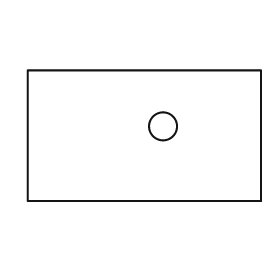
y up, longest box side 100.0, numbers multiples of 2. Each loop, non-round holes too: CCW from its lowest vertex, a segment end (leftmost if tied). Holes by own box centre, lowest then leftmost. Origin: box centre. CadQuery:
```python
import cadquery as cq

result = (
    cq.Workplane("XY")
    .moveTo(-50.0, -28.0)
    .lineTo(50.0, -28.0)
    .lineTo(50.0, 28.0)
    .lineTo(-50.0, 28.0)
    .close()
    .moveTo(8.0, 4.0)
    .circle(6.0)
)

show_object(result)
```